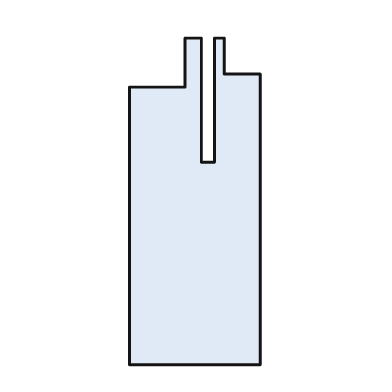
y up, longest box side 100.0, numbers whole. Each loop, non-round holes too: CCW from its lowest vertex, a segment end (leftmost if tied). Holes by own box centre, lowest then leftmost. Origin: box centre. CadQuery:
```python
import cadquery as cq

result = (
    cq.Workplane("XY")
    .moveTo(-20.0, -50.0)
    .lineTo(20.0, -50.0)
    .lineTo(20.0, 39.0)
    .lineTo(9.0, 39.0)
    .lineTo(9.0, 50.0)
    .lineTo(6.0, 50.0)
    .lineTo(6.0, 12.0)
    .lineTo(2.0, 12.0)
    .lineTo(2.0, 50.0)
    .lineTo(-3.0, 50.0)
    .lineTo(-3.0, 35.0)
    .lineTo(-20.0, 35.0)
    .close()
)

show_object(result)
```